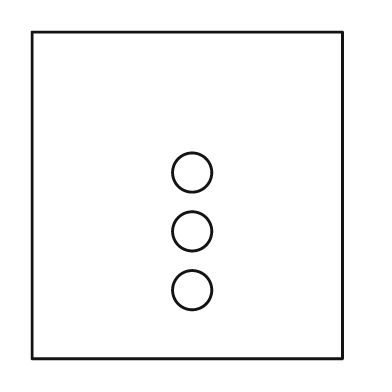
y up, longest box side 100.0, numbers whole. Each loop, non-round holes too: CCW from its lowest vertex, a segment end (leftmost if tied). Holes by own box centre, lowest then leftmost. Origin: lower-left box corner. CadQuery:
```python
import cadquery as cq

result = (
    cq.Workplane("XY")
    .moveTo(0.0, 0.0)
    .lineTo(95.0, 0.0)
    .lineTo(95.0, 100.0)
    .lineTo(0.0, 100.0)
    .close()
    .moveTo(49.0, 21.0)
    .circle(6.0)
    .moveTo(49.0, 39.0)
    .circle(6.0)
    .moveTo(49.0, 57.0)
    .circle(6.0)
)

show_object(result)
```